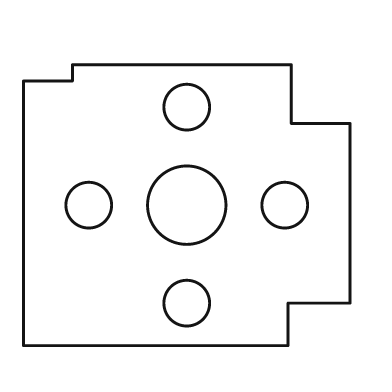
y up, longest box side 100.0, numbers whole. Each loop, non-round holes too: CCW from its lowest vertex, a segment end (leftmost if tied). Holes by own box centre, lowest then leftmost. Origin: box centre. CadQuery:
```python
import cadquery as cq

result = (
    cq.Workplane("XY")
    .moveTo(-50.0, -43.0)
    .lineTo(31.0, -43.0)
    .lineTo(31.0, -30.0)
    .lineTo(50.0, -30.0)
    .lineTo(50.0, 25.0)
    .lineTo(32.0, 25.0)
    .lineTo(32.0, 43.0)
    .lineTo(-35.0, 43.0)
    .lineTo(-35.0, 38.0)
    .lineTo(-50.0, 38.0)
    .close()
    .moveTo(0.0, -30.0)
    .circle(7.0)
    .moveTo(-30.0, 0.0)
    .circle(7.0)
    .moveTo(0.0, 0.0)
    .circle(12.0)
    .moveTo(30.0, 0.0)
    .circle(7.0)
    .moveTo(0.0, 30.0)
    .circle(7.0)
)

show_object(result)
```